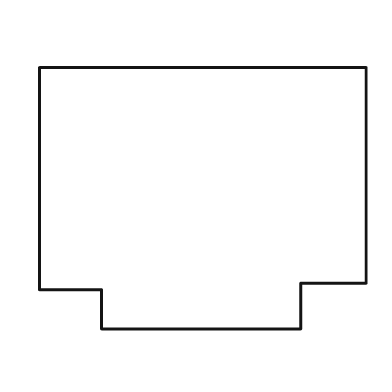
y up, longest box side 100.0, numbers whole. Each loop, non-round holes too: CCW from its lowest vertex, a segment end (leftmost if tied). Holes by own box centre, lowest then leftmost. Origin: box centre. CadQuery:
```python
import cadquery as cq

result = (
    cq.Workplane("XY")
    .moveTo(-31.0, -40.0)
    .lineTo(30.0, -40.0)
    .lineTo(30.0, -26.0)
    .lineTo(50.0, -26.0)
    .lineTo(50.0, 40.0)
    .lineTo(-50.0, 40.0)
    .lineTo(-50.0, -28.0)
    .lineTo(-31.0, -28.0)
    .close()
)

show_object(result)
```